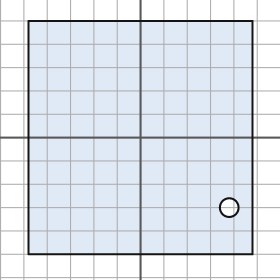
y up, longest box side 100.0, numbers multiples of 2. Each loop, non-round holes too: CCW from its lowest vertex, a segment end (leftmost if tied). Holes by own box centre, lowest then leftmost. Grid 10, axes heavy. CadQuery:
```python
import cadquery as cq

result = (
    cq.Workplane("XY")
    .moveTo(-48.0, -50.0)
    .lineTo(48.0, -50.0)
    .lineTo(48.0, 50.0)
    .lineTo(-48.0, 50.0)
    .close()
    .moveTo(38.0, -30.0)
    .circle(4.0)
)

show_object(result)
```